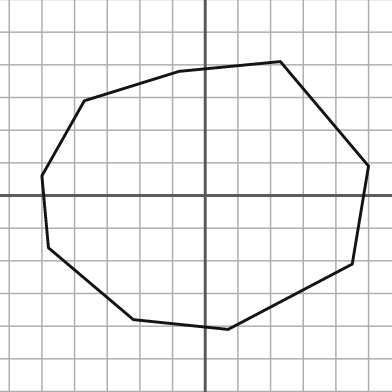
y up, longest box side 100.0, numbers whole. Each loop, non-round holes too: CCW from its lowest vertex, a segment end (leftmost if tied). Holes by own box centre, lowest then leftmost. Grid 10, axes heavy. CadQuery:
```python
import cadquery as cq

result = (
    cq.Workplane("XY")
    .moveTo(7.0, -41.0)
    .lineTo(45.0, -21.0)
    .lineTo(50.0, 9.0)
    .lineTo(23.0, 41.0)
    .lineTo(-8.0, 38.0)
    .lineTo(-37.0, 29.0)
    .lineTo(-50.0, 6.0)
    .lineTo(-48.0, -16.0)
    .lineTo(-22.0, -38.0)
    .close()
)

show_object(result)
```